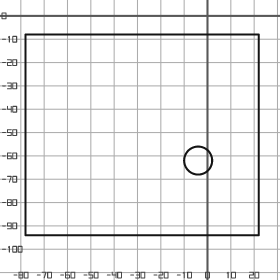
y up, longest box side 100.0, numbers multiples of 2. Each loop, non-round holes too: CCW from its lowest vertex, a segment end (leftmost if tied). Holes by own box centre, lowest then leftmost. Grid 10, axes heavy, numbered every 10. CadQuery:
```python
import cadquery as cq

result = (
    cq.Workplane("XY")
    .moveTo(-78.0, -94.0)
    .lineTo(22.0, -94.0)
    .lineTo(22.0, -8.0)
    .lineTo(-78.0, -8.0)
    .close()
    .moveTo(-4.0, -62.0)
    .circle(6.0)
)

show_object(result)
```